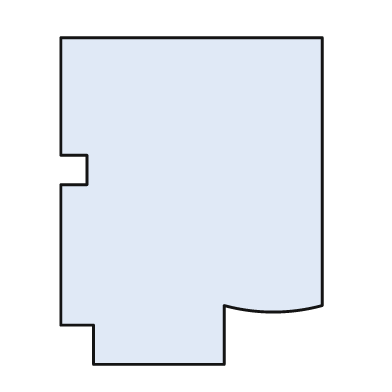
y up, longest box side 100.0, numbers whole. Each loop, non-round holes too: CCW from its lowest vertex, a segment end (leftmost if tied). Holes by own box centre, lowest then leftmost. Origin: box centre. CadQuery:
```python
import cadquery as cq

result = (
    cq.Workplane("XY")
    .moveTo(-30.0, -50.0)
    .lineTo(10.0, -50.0)
    .lineTo(10.0, -32.0)
    .threePointArc((25.0, -34.0), (40.0, -32.0))
    .lineTo(40.0, 50.0)
    .lineTo(-40.0, 50.0)
    .lineTo(-40.0, 14.0)
    .lineTo(-32.0, 14.0)
    .lineTo(-32.0, 5.0)
    .lineTo(-40.0, 5.0)
    .lineTo(-40.0, -38.0)
    .lineTo(-30.0, -38.0)
    .close()
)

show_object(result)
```